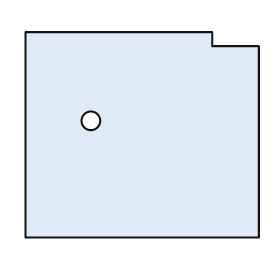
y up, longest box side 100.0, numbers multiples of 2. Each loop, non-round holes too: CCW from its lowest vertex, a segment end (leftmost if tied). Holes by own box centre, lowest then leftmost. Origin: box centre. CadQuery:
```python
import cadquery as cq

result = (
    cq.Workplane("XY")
    .moveTo(-50.0, -44.0)
    .lineTo(50.0, -44.0)
    .lineTo(50.0, 38.0)
    .lineTo(30.0, 38.0)
    .lineTo(30.0, 44.0)
    .lineTo(-50.0, 44.0)
    .close()
    .moveTo(-22.0, 6.0)
    .circle(4.0)
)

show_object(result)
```